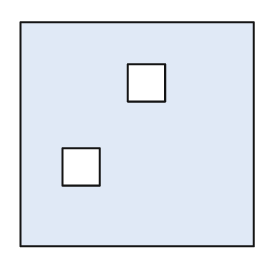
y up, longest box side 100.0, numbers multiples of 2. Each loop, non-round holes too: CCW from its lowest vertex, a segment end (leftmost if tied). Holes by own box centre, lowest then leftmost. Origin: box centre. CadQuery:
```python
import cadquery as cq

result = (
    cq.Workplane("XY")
    .moveTo(-50.0, -48.0)
    .lineTo(50.0, -48.0)
    .lineTo(50.0, 48.0)
    .lineTo(-50.0, 48.0)
    .close()
    .moveTo(-32.0, -22.0)
    .lineTo(-16.0, -22.0)
    .lineTo(-16.0, -6.0)
    .lineTo(-32.0, -6.0)
    .close()
    .moveTo(-4.0, 14.0)
    .lineTo(12.0, 14.0)
    .lineTo(12.0, 30.0)
    .lineTo(-4.0, 30.0)
    .close()
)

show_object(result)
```